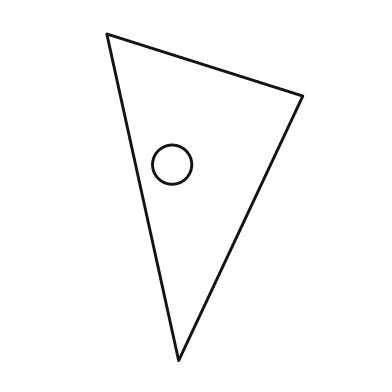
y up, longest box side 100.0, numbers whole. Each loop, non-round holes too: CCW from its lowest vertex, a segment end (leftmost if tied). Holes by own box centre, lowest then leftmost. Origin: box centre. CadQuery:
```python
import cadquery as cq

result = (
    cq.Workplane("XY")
    .moveTo(-8.0, -50.0)
    .lineTo(30.0, 31.0)
    .lineTo(-30.0, 50.0)
    .close()
    .moveTo(-10.0, 10.0)
    .circle(6.0)
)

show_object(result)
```